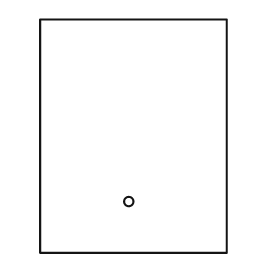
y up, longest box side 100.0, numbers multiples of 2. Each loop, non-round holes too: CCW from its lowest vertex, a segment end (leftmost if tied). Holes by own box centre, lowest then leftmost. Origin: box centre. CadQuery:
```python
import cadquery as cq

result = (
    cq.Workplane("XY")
    .moveTo(-40.0, -50.0)
    .lineTo(40.0, -50.0)
    .lineTo(40.0, 50.0)
    .lineTo(-40.0, 50.0)
    .close()
    .moveTo(-2.0, -28.0)
    .circle(2.0)
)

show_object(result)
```